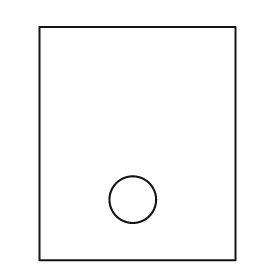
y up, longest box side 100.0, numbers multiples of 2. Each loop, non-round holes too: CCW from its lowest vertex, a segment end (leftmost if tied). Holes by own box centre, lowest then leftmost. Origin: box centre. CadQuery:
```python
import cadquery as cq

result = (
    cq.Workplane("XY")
    .moveTo(-42.0, -50.0)
    .lineTo(42.0, -50.0)
    .lineTo(42.0, 50.0)
    .lineTo(-42.0, 50.0)
    .close()
    .moveTo(-2.0, -24.0)
    .circle(10.0)
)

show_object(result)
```